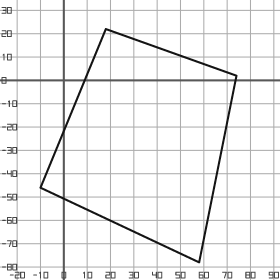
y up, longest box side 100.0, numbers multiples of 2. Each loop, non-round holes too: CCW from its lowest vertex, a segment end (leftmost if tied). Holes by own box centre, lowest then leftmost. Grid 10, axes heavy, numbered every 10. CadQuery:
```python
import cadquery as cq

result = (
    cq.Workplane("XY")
    .moveTo(58.0, -78.0)
    .lineTo(74.0, 2.0)
    .lineTo(18.0, 22.0)
    .lineTo(-10.0, -46.0)
    .close()
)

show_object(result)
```